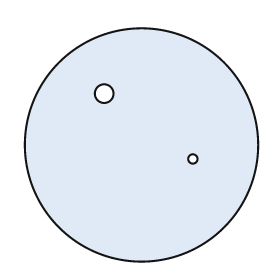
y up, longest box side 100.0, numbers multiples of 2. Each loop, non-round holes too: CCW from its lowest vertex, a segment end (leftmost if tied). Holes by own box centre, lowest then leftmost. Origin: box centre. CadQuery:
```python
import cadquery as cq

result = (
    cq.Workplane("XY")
    .moveTo(0.0, 0.0)
    .circle(50.0)
    .moveTo(22.0, -6.0)
    .circle(2.0)
    .moveTo(-16.0, 22.0)
    .circle(4.0)
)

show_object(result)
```